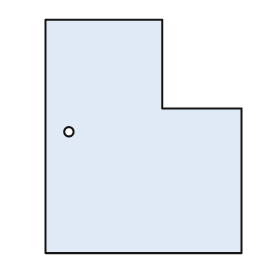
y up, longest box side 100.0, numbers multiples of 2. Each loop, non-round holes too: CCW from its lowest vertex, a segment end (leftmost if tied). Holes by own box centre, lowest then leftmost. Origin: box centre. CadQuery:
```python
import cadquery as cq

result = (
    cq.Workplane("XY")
    .moveTo(-42.0, -50.0)
    .lineTo(42.0, -50.0)
    .lineTo(42.0, 12.0)
    .lineTo(8.0, 12.0)
    .lineTo(8.0, 50.0)
    .lineTo(-42.0, 50.0)
    .close()
    .moveTo(-32.0, 2.0)
    .circle(2.0)
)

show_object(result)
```